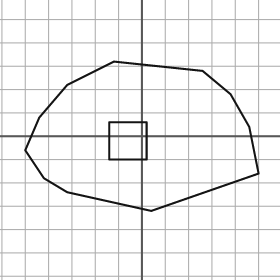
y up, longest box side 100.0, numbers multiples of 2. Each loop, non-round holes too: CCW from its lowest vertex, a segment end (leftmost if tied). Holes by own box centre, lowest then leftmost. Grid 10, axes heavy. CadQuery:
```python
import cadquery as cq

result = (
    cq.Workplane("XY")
    .moveTo(4.0, -32.0)
    .lineTo(50.0, -16.0)
    .lineTo(46.0, 4.0)
    .lineTo(38.0, 18.0)
    .lineTo(26.0, 28.0)
    .lineTo(-12.0, 32.0)
    .lineTo(-32.0, 22.0)
    .lineTo(-44.0, 8.0)
    .lineTo(-50.0, -6.0)
    .lineTo(-42.0, -18.0)
    .lineTo(-32.0, -24.0)
    .close()
    .moveTo(-14.0, -10.0)
    .lineTo(2.0, -10.0)
    .lineTo(2.0, 6.0)
    .lineTo(-14.0, 6.0)
    .close()
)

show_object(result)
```